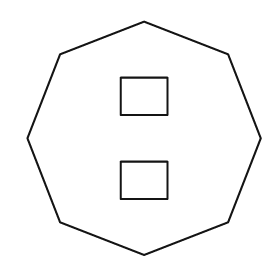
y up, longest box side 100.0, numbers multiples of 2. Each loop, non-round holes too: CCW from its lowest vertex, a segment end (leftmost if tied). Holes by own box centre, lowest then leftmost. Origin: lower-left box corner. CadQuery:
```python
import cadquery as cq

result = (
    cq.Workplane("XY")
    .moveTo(50.0, 0.0)
    .lineTo(86.0, 14.0)
    .lineTo(100.0, 50.0)
    .lineTo(86.0, 86.0)
    .lineTo(50.0, 100.0)
    .lineTo(14.0, 86.0)
    .lineTo(0.0, 50.0)
    .lineTo(14.0, 14.0)
    .close()
    .moveTo(40.0, 24.0)
    .lineTo(60.0, 24.0)
    .lineTo(60.0, 40.0)
    .lineTo(40.0, 40.0)
    .close()
    .moveTo(40.0, 60.0)
    .lineTo(60.0, 60.0)
    .lineTo(60.0, 76.0)
    .lineTo(40.0, 76.0)
    .close()
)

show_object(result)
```